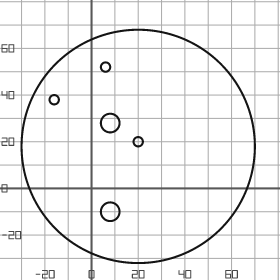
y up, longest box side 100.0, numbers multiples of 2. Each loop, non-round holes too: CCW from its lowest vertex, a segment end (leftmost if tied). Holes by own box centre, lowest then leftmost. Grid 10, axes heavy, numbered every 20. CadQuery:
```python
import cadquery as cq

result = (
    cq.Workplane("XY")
    .moveTo(20.0, 18.0)
    .circle(50.0)
    .moveTo(8.0, -10.0)
    .circle(4.0)
    .moveTo(20.0, 20.0)
    .circle(2.0)
    .moveTo(8.0, 28.0)
    .circle(4.0)
    .moveTo(-16.0, 38.0)
    .circle(2.0)
    .moveTo(6.0, 52.0)
    .circle(2.0)
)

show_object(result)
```